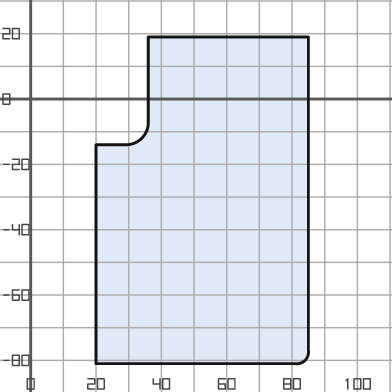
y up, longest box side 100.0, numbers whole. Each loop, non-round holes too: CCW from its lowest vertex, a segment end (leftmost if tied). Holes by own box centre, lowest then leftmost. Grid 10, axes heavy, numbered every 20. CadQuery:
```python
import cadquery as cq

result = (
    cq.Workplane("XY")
    .moveTo(20.0, -81.0)
    .lineTo(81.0, -81.0)
    .threePointArc((84.0, -80.0), (85.0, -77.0))
    .lineTo(85.0, 19.0)
    .lineTo(36.0, 19.0)
    .lineTo(36.0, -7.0)
    .threePointArc((34.0, -12.0), (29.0, -14.0))
    .lineTo(20.0, -14.0)
    .close()
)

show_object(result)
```